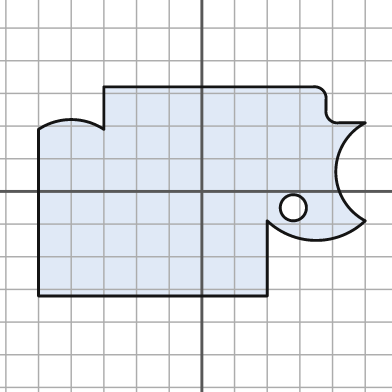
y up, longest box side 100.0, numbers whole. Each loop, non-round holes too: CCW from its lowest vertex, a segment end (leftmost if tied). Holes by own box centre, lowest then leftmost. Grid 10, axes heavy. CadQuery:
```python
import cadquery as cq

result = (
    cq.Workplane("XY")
    .moveTo(-50.0, -32.0)
    .lineTo(20.0, -32.0)
    .lineTo(20.0, -9.0)
    .threePointArc((35.0, -15.0), (50.0, -9.0))
    .threePointArc((41.0, 6.0), (50.0, 21.0))
    .lineTo(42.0, 21.0)
    .threePointArc((39.0, 22.0), (38.0, 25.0))
    .lineTo(38.0, 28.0)
    .threePointArc((37.0, 31.0), (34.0, 32.0))
    .lineTo(-30.0, 32.0)
    .lineTo(-30.0, 19.0)
    .threePointArc((-40.0, 22.0), (-50.0, 19.0))
    .close()
    .moveTo(28.0, -5.0)
    .circle(4.0)
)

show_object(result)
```